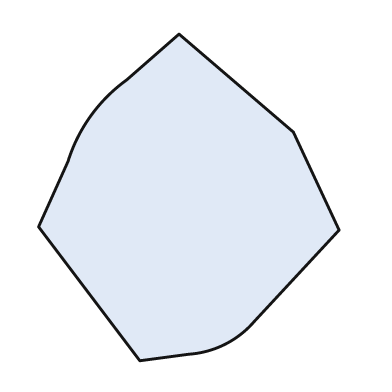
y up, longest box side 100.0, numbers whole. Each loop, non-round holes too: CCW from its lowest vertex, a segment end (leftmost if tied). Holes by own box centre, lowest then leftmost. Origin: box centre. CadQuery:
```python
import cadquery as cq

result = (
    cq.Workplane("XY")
    .moveTo(-15.0, -50.0)
    .lineTo(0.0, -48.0)
    .threePointArc((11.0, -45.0), (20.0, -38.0))
    .lineTo(46.0, -10.0)
    .lineTo(32.0, 20.0)
    .lineTo(-3.0, 50.0)
    .lineTo(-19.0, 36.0)
    .threePointArc((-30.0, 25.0), (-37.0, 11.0))
    .lineTo(-46.0, -9.0)
    .close()
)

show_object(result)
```